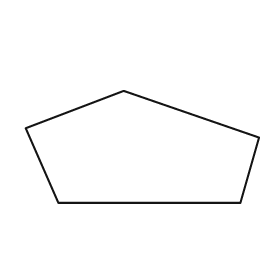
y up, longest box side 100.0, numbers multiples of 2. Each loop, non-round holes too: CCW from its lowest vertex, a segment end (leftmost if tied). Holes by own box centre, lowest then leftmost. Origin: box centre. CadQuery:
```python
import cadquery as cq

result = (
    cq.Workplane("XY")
    .moveTo(-36.0, -24.0)
    .lineTo(42.0, -24.0)
    .lineTo(50.0, 4.0)
    .lineTo(-8.0, 24.0)
    .lineTo(-50.0, 8.0)
    .close()
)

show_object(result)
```